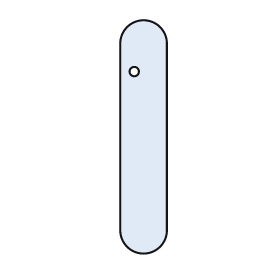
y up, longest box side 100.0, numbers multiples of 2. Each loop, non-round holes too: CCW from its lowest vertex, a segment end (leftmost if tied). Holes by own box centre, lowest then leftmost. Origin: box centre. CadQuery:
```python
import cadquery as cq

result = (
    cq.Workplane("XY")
    .moveTo(-10.0, -40.0)
    .threePointArc((0.0, -50.0), (10.0, -40.0))
    .lineTo(10.0, 40.0)
    .threePointArc((0.0, 50.0), (-10.0, 40.0))
    .close()
    .moveTo(-4.0, 28.0)
    .circle(2.0)
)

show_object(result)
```